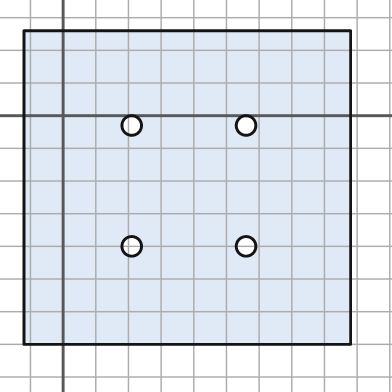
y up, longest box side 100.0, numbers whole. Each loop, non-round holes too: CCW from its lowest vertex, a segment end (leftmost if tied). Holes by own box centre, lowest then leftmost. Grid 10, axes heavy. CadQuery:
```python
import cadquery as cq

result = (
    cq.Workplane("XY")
    .moveTo(-12.0, -70.0)
    .lineTo(88.0, -70.0)
    .lineTo(88.0, 26.0)
    .lineTo(-12.0, 26.0)
    .close()
    .moveTo(21.0, -40.0)
    .circle(3.0)
    .moveTo(56.0, -40.0)
    .circle(3.0)
    .moveTo(21.0, -3.0)
    .circle(3.0)
    .moveTo(56.0, -3.0)
    .circle(3.0)
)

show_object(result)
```